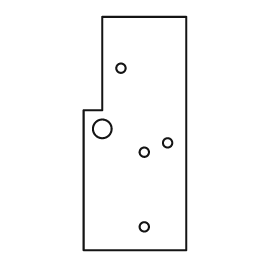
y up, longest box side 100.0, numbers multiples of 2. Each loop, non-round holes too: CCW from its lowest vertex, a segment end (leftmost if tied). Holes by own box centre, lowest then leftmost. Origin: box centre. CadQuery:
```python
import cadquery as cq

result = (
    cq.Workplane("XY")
    .moveTo(-22.0, -50.0)
    .lineTo(22.0, -50.0)
    .lineTo(22.0, 50.0)
    .lineTo(-14.0, 50.0)
    .lineTo(-14.0, 10.0)
    .lineTo(-22.0, 10.0)
    .close()
    .moveTo(4.0, -40.0)
    .circle(2.0)
    .moveTo(4.0, -8.0)
    .circle(2.0)
    .moveTo(14.0, -4.0)
    .circle(2.0)
    .moveTo(-14.0, 2.0)
    .circle(4.0)
    .moveTo(-6.0, 28.0)
    .circle(2.0)
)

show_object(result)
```